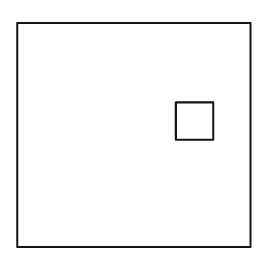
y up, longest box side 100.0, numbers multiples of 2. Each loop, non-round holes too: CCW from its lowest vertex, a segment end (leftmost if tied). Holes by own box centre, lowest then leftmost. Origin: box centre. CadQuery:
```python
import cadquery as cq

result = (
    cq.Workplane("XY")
    .moveTo(-50.0, -48.0)
    .lineTo(50.0, -48.0)
    .lineTo(50.0, 48.0)
    .lineTo(-50.0, 48.0)
    .close()
    .moveTo(18.0, -2.0)
    .lineTo(34.0, -2.0)
    .lineTo(34.0, 14.0)
    .lineTo(18.0, 14.0)
    .close()
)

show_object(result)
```